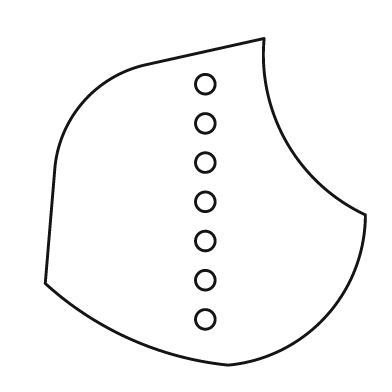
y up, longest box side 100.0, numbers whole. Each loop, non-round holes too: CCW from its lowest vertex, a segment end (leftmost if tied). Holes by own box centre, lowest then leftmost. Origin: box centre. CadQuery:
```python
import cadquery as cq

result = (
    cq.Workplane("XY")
    .moveTo(7.0, -50.0)
    .threePointArc((37.0, -35.0), (49.0, -4.0))
    .threePointArc((25.0, 18.0), (18.0, 50.0))
    .lineTo(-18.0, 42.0)
    .threePointArc((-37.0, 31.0), (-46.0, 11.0))
    .lineTo(-49.0, -25.0)
    .threePointArc((-23.0, -42.0), (7.0, -50.0))
    .close()
    .moveTo(0.0, -36.0)
    .circle(3.0)
    .moveTo(0.0, -24.0)
    .circle(3.0)
    .moveTo(0.0, -12.0)
    .circle(3.0)
    .moveTo(0.0, 0.0)
    .circle(3.0)
    .moveTo(0.0, 12.0)
    .circle(3.0)
    .moveTo(0.0, 24.0)
    .circle(3.0)
    .moveTo(0.0, 36.0)
    .circle(3.0)
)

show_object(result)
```